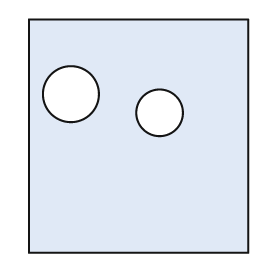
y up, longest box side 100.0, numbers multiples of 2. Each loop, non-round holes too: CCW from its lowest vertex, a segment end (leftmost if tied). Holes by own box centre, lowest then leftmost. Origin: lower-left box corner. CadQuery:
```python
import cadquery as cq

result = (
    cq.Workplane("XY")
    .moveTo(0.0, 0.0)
    .lineTo(94.0, 0.0)
    .lineTo(94.0, 100.0)
    .lineTo(0.0, 100.0)
    .close()
    .moveTo(56.0, 60.0)
    .circle(10.0)
    .moveTo(18.0, 68.0)
    .circle(12.0)
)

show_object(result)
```